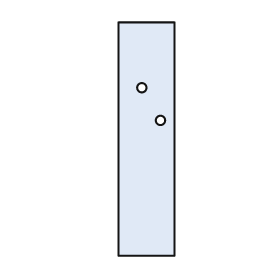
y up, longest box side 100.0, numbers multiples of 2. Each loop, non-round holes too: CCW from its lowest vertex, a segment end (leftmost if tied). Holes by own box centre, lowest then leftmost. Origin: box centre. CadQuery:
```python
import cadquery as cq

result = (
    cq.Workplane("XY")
    .moveTo(-12.0, -50.0)
    .lineTo(12.0, -50.0)
    .lineTo(12.0, 50.0)
    .lineTo(-12.0, 50.0)
    .close()
    .moveTo(6.0, 8.0)
    .circle(2.0)
    .moveTo(-2.0, 22.0)
    .circle(2.0)
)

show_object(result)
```